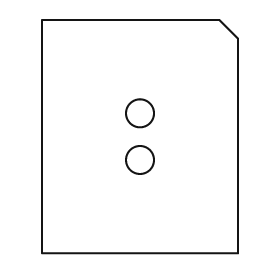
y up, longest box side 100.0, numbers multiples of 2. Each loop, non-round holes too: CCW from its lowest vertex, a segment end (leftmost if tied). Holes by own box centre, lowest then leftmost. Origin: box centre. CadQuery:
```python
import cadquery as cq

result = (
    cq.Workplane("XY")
    .moveTo(-42.0, -50.0)
    .lineTo(42.0, -50.0)
    .lineTo(42.0, 42.0)
    .lineTo(34.0, 50.0)
    .lineTo(-42.0, 50.0)
    .close()
    .moveTo(0.0, -10.0)
    .circle(6.0)
    .moveTo(0.0, 10.0)
    .circle(6.0)
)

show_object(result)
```